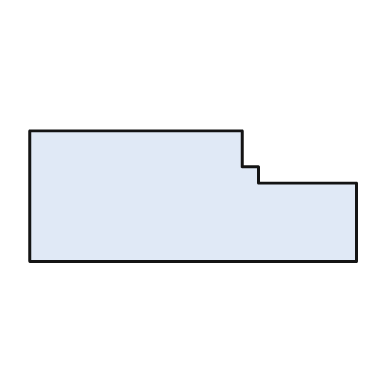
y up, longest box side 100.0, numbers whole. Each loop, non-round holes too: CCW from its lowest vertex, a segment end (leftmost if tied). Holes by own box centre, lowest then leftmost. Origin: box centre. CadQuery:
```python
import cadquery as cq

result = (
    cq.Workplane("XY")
    .moveTo(-50.0, -20.0)
    .lineTo(50.0, -20.0)
    .lineTo(50.0, 4.0)
    .lineTo(20.0, 4.0)
    .lineTo(20.0, 9.0)
    .lineTo(15.0, 9.0)
    .lineTo(15.0, 20.0)
    .lineTo(-50.0, 20.0)
    .close()
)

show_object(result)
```